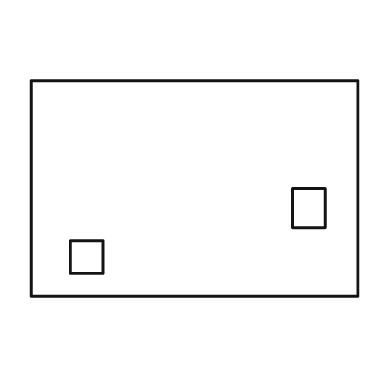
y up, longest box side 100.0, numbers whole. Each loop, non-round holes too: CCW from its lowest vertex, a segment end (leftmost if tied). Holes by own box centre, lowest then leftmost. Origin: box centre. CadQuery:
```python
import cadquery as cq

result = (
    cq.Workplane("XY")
    .moveTo(-50.0, -33.0)
    .lineTo(50.0, -33.0)
    .lineTo(50.0, 33.0)
    .lineTo(-50.0, 33.0)
    .close()
    .moveTo(-38.0, -26.0)
    .lineTo(-28.0, -26.0)
    .lineTo(-28.0, -16.0)
    .lineTo(-38.0, -16.0)
    .close()
    .moveTo(30.0, -12.0)
    .lineTo(40.0, -12.0)
    .lineTo(40.0, 0.0)
    .lineTo(30.0, 0.0)
    .close()
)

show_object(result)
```